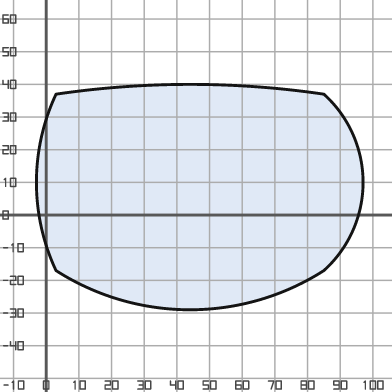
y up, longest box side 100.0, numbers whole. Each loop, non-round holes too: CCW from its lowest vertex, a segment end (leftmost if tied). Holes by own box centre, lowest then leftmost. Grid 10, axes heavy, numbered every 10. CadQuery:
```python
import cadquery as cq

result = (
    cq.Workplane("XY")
    .moveTo(3.0, -17.0)
    .threePointArc((44.0, -29.0), (85.0, -17.0))
    .threePointArc((97.0, 10.0), (85.0, 37.0))
    .threePointArc((44.0, 40.0), (3.0, 37.0))
    .threePointArc((-3.0, 10.0), (3.0, -17.0))
    .close()
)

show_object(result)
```